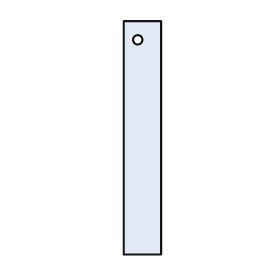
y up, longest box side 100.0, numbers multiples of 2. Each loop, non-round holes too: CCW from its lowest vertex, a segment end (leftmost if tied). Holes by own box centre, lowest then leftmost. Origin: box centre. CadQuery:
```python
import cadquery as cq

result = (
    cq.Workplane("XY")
    .moveTo(-8.0, -50.0)
    .lineTo(8.0, -50.0)
    .lineTo(8.0, 50.0)
    .lineTo(-8.0, 50.0)
    .close()
    .moveTo(-2.0, 42.0)
    .circle(2.0)
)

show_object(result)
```